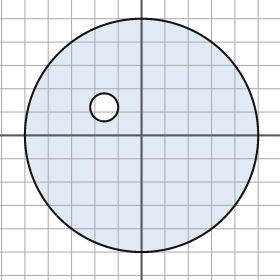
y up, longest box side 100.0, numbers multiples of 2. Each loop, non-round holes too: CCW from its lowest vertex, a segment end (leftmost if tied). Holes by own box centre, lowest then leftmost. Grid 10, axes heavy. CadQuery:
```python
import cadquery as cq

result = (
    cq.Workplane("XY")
    .moveTo(0.0, 0.0)
    .circle(50.0)
    .moveTo(-16.0, 12.0)
    .circle(6.0)
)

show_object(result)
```